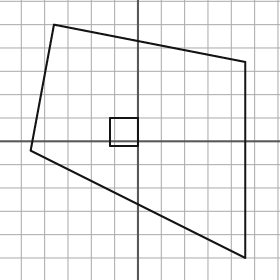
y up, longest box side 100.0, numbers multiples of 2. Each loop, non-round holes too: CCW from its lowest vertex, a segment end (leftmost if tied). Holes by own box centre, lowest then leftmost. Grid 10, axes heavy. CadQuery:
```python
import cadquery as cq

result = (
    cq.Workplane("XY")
    .moveTo(46.0, -50.0)
    .lineTo(46.0, 34.0)
    .lineTo(-36.0, 50.0)
    .lineTo(-46.0, -4.0)
    .close()
    .moveTo(-12.0, -2.0)
    .lineTo(0.0, -2.0)
    .lineTo(0.0, 10.0)
    .lineTo(-12.0, 10.0)
    .close()
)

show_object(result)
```